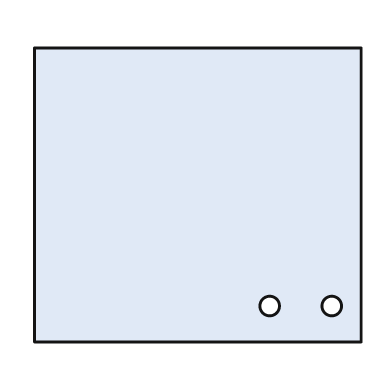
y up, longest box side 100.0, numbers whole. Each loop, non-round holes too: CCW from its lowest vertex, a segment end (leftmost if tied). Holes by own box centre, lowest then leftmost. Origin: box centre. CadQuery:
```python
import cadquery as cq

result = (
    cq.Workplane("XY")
    .moveTo(-50.0, -45.0)
    .lineTo(50.0, -45.0)
    .lineTo(50.0, 45.0)
    .lineTo(-50.0, 45.0)
    .close()
    .moveTo(22.0, -34.0)
    .circle(3.0)
    .moveTo(41.0, -34.0)
    .circle(3.0)
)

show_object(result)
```